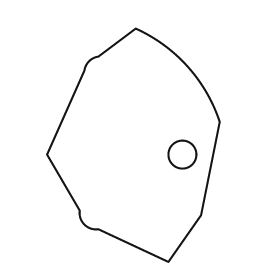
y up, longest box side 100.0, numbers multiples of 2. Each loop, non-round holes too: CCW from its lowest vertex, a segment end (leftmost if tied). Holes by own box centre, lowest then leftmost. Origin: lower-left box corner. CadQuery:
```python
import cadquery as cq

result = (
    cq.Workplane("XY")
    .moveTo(52.0, 0.0)
    .lineTo(66.0, 20.0)
    .lineTo(74.0, 60.0)
    .threePointArc((60.0, 84.0), (38.0, 100.0))
    .lineTo(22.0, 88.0)
    .threePointArc((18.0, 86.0), (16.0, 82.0))
    .lineTo(0.0, 46.0)
    .lineTo(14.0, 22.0)
    .threePointArc((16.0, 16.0), (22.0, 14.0))
    .close()
    .moveTo(58.0, 46.0)
    .circle(6.0)
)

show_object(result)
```